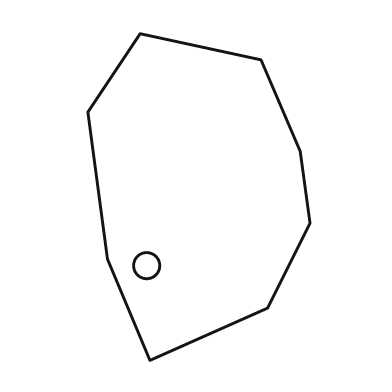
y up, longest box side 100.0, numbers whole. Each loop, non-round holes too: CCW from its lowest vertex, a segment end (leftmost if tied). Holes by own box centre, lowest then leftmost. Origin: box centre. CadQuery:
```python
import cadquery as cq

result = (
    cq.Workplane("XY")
    .moveTo(-15.0, -50.0)
    .lineTo(21.0, -34.0)
    .lineTo(34.0, -8.0)
    .lineTo(31.0, 14.0)
    .lineTo(19.0, 42.0)
    .lineTo(-18.0, 50.0)
    .lineTo(-34.0, 26.0)
    .lineTo(-28.0, -19.0)
    .close()
    .moveTo(-16.0, -21.0)
    .circle(4.0)
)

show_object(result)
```